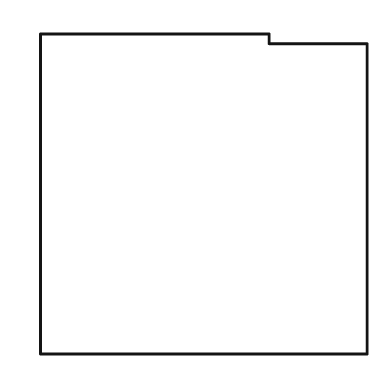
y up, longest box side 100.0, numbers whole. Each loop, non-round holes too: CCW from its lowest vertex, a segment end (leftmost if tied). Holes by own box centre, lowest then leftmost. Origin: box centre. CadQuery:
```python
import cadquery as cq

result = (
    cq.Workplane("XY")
    .moveTo(-50.0, -49.0)
    .lineTo(50.0, -49.0)
    .lineTo(50.0, 46.0)
    .lineTo(20.0, 46.0)
    .lineTo(20.0, 49.0)
    .lineTo(-50.0, 49.0)
    .close()
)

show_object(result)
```